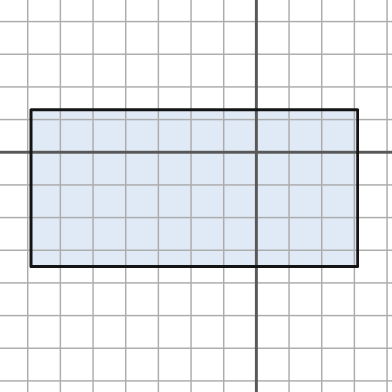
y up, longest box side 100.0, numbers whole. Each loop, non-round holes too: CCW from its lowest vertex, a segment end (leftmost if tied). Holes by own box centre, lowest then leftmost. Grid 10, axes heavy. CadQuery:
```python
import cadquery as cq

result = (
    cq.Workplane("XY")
    .moveTo(-69.0, -35.0)
    .lineTo(31.0, -35.0)
    .lineTo(31.0, 13.0)
    .lineTo(-69.0, 13.0)
    .close()
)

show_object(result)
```